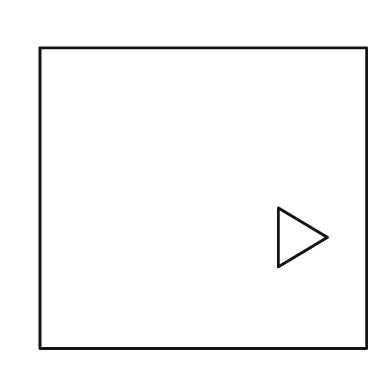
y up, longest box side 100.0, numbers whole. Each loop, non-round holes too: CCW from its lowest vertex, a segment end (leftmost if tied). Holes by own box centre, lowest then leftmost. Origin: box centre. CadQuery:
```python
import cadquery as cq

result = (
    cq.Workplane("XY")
    .moveTo(-50.0, -46.0)
    .lineTo(50.0, -46.0)
    .lineTo(50.0, 46.0)
    .lineTo(-50.0, 46.0)
    .close()
    .moveTo(23.0, -21.0)
    .lineTo(38.0, -12.0)
    .lineTo(23.0, -3.0)
    .close()
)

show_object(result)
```